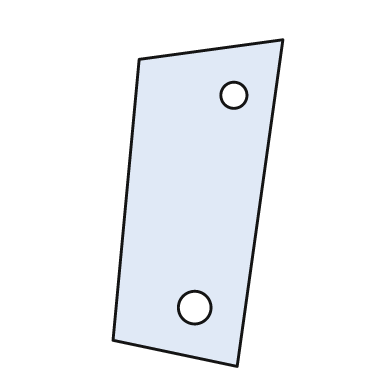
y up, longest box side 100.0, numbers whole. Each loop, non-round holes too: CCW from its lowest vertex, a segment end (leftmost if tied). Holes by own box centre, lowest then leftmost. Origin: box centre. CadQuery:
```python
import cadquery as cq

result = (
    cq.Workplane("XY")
    .moveTo(12.0, -50.0)
    .lineTo(26.0, 50.0)
    .lineTo(-18.0, 44.0)
    .lineTo(-26.0, -42.0)
    .close()
    .moveTo(-1.0, -32.0)
    .circle(5.0)
    .moveTo(11.0, 33.0)
    .circle(4.0)
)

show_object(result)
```